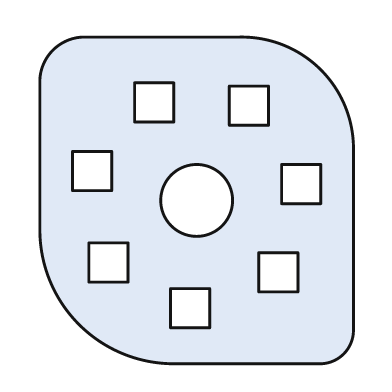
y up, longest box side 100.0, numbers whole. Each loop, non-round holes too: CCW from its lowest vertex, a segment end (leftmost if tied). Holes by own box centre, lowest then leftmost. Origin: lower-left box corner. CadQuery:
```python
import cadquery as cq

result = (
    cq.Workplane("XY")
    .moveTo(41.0, 0.0)
    .lineTo(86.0, 0.0)
    .threePointArc((93.0, 3.0), (96.0, 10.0))
    .lineTo(96.0, 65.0)
    .threePointArc((86.0, 90.0), (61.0, 100.0))
    .lineTo(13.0, 100.0)
    .threePointArc((4.0, 96.0), (0.0, 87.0))
    .lineTo(0.0, 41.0)
    .threePointArc((12.0, 12.0), (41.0, 0.0))
    .close()
    .moveTo(40.0, 11.0)
    .lineTo(52.0, 11.0)
    .lineTo(52.0, 23.0)
    .lineTo(40.0, 23.0)
    .close()
    .moveTo(67.0, 22.0)
    .lineTo(79.0, 22.0)
    .lineTo(79.0, 34.0)
    .lineTo(67.0, 34.0)
    .close()
    .moveTo(15.0, 25.0)
    .lineTo(27.0, 25.0)
    .lineTo(27.0, 37.0)
    .lineTo(15.0, 37.0)
    .close()
    .moveTo(48.0, 50.0)
    .circle(11.0)
    .moveTo(74.0, 49.0)
    .lineTo(86.0, 49.0)
    .lineTo(86.0, 61.0)
    .lineTo(74.0, 61.0)
    .close()
    .moveTo(10.0, 53.0)
    .lineTo(22.0, 53.0)
    .lineTo(22.0, 65.0)
    .lineTo(10.0, 65.0)
    .close()
    .moveTo(58.0, 73.0)
    .lineTo(70.0, 73.0)
    .lineTo(70.0, 85.0)
    .lineTo(58.0, 85.0)
    .close()
    .moveTo(29.0, 74.0)
    .lineTo(41.0, 74.0)
    .lineTo(41.0, 86.0)
    .lineTo(29.0, 86.0)
    .close()
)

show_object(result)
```